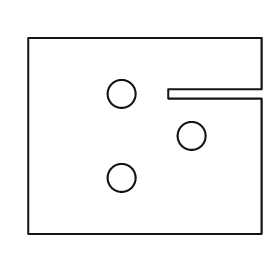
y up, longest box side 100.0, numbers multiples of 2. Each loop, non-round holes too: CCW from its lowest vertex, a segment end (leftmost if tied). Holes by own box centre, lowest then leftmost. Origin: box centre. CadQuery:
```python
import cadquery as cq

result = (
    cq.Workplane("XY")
    .moveTo(-50.0, -42.0)
    .lineTo(50.0, -42.0)
    .lineTo(50.0, 16.0)
    .lineTo(10.0, 16.0)
    .lineTo(10.0, 20.0)
    .lineTo(50.0, 20.0)
    .lineTo(50.0, 42.0)
    .lineTo(-50.0, 42.0)
    .close()
    .moveTo(-10.0, -18.0)
    .circle(6.0)
    .moveTo(20.0, 0.0)
    .circle(6.0)
    .moveTo(-10.0, 18.0)
    .circle(6.0)
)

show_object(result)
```